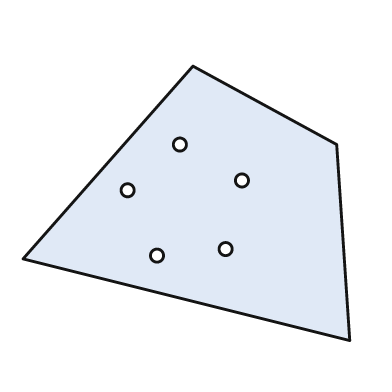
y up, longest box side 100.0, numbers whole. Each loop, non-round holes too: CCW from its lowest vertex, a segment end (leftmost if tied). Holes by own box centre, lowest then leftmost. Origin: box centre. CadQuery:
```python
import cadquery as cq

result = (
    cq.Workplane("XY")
    .moveTo(50.0, -42.0)
    .lineTo(46.0, 18.0)
    .lineTo(2.0, 42.0)
    .lineTo(-50.0, -17.0)
    .close()
    .moveTo(-9.0, -16.0)
    .circle(2.0)
    .moveTo(12.0, -14.0)
    .circle(2.0)
    .moveTo(-18.0, 4.0)
    .circle(2.0)
    .moveTo(17.0, 7.0)
    .circle(2.0)
    .moveTo(-2.0, 18.0)
    .circle(2.0)
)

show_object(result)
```